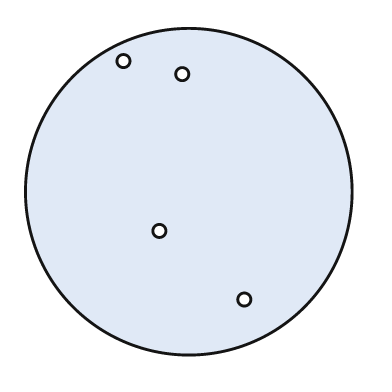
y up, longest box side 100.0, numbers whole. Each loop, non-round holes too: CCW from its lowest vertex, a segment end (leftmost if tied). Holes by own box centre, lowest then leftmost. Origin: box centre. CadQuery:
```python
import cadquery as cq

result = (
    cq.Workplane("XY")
    .moveTo(0.0, 0.0)
    .circle(50.0)
    .moveTo(17.0, -33.0)
    .circle(2.0)
    .moveTo(-9.0, -12.0)
    .circle(2.0)
    .moveTo(-2.0, 36.0)
    .circle(2.0)
    .moveTo(-20.0, 40.0)
    .circle(2.0)
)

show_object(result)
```